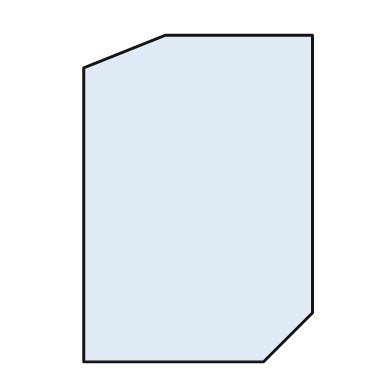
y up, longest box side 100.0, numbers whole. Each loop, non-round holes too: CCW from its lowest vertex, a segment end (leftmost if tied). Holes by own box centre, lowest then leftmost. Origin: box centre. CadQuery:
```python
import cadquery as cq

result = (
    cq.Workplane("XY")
    .moveTo(-35.0, -50.0)
    .lineTo(20.0, -50.0)
    .lineTo(35.0, -35.0)
    .lineTo(35.0, 50.0)
    .lineTo(-10.0, 50.0)
    .lineTo(-35.0, 40.0)
    .close()
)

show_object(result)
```